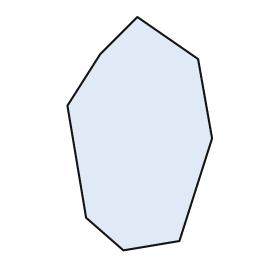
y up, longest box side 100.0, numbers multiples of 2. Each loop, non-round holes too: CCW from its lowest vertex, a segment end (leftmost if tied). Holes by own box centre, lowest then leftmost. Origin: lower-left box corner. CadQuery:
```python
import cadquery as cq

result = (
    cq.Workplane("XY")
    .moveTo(24.0, 0.0)
    .lineTo(48.0, 4.0)
    .lineTo(62.0, 48.0)
    .lineTo(56.0, 82.0)
    .lineTo(30.0, 100.0)
    .lineTo(14.0, 84.0)
    .lineTo(0.0, 62.0)
    .lineTo(8.0, 14.0)
    .close()
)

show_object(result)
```